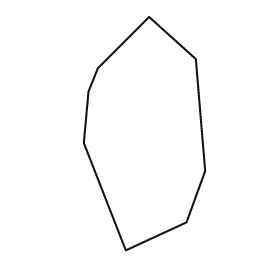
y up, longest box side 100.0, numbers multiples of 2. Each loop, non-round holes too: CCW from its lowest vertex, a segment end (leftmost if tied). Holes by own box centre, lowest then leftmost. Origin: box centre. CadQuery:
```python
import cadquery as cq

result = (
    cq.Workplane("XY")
    .moveTo(-8.0, -50.0)
    .lineTo(18.0, -38.0)
    .lineTo(26.0, -16.0)
    .lineTo(22.0, 32.0)
    .lineTo(2.0, 50.0)
    .lineTo(-20.0, 28.0)
    .lineTo(-24.0, 18.0)
    .lineTo(-26.0, -4.0)
    .close()
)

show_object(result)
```